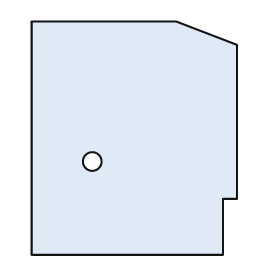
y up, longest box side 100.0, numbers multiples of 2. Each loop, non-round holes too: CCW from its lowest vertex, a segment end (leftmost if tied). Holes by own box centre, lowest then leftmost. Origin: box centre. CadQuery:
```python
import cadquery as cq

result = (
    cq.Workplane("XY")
    .moveTo(-44.0, -50.0)
    .lineTo(38.0, -50.0)
    .lineTo(38.0, -26.0)
    .lineTo(44.0, -26.0)
    .lineTo(44.0, 40.0)
    .lineTo(18.0, 50.0)
    .lineTo(-44.0, 50.0)
    .close()
    .moveTo(-18.0, -10.0)
    .circle(4.0)
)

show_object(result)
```